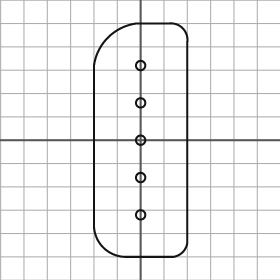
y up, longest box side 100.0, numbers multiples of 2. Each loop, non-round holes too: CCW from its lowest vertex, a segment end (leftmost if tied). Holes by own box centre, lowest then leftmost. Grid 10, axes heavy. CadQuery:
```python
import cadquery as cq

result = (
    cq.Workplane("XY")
    .moveTo(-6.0, -50.0)
    .lineTo(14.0, -50.0)
    .threePointArc((18.0, -48.0), (20.0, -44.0))
    .lineTo(20.0, 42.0)
    .threePointArc((18.0, 48.0), (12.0, 50.0))
    .lineTo(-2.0, 50.0)
    .threePointArc((-14.0, 44.0), (-20.0, 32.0))
    .lineTo(-20.0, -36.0)
    .threePointArc((-16.0, -46.0), (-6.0, -50.0))
    .close()
    .moveTo(0.0, -32.0)
    .circle(2.0)
    .moveTo(0.0, -16.0)
    .circle(2.0)
    .moveTo(0.0, 0.0)
    .circle(2.0)
    .moveTo(0.0, 16.0)
    .circle(2.0)
    .moveTo(0.0, 32.0)
    .circle(2.0)
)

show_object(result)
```